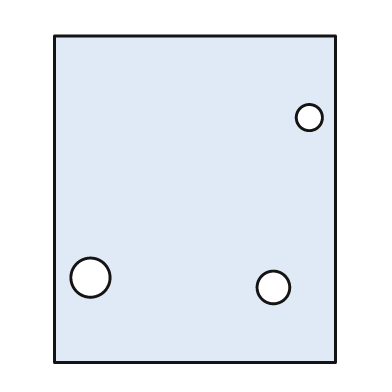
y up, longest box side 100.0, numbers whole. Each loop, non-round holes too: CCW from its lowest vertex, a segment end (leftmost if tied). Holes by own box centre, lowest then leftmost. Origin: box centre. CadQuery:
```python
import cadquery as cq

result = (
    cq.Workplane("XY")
    .moveTo(-43.0, -50.0)
    .lineTo(43.0, -50.0)
    .lineTo(43.0, 50.0)
    .lineTo(-43.0, 50.0)
    .close()
    .moveTo(24.0, -27.0)
    .circle(5.0)
    .moveTo(-32.0, -24.0)
    .circle(6.0)
    .moveTo(35.0, 25.0)
    .circle(4.0)
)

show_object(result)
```